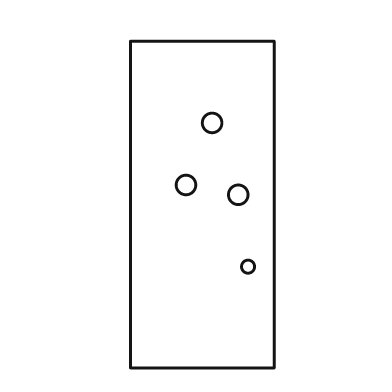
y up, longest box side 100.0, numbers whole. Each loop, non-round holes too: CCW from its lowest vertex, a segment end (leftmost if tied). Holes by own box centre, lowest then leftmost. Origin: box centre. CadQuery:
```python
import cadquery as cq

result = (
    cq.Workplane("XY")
    .moveTo(-22.0, -50.0)
    .lineTo(22.0, -50.0)
    .lineTo(22.0, 50.0)
    .lineTo(-22.0, 50.0)
    .close()
    .moveTo(14.0, -19.0)
    .circle(2.0)
    .moveTo(11.0, 3.0)
    .circle(3.0)
    .moveTo(-5.0, 6.0)
    .circle(3.0)
    .moveTo(3.0, 25.0)
    .circle(3.0)
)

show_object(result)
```